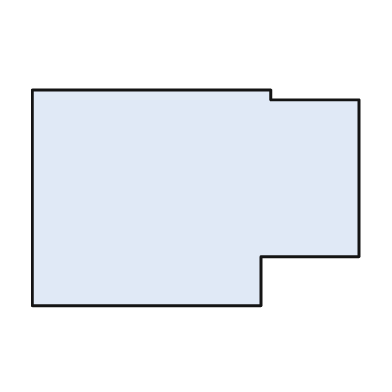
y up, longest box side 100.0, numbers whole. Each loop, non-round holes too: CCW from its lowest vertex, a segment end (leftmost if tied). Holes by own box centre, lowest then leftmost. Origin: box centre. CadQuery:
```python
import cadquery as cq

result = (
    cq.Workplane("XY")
    .moveTo(-50.0, -33.0)
    .lineTo(20.0, -33.0)
    .lineTo(20.0, -18.0)
    .lineTo(50.0, -18.0)
    .lineTo(50.0, 30.0)
    .lineTo(23.0, 30.0)
    .lineTo(23.0, 33.0)
    .lineTo(-50.0, 33.0)
    .close()
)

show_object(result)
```